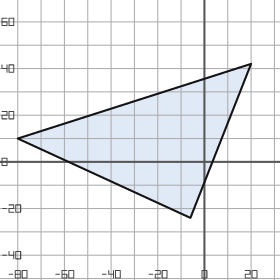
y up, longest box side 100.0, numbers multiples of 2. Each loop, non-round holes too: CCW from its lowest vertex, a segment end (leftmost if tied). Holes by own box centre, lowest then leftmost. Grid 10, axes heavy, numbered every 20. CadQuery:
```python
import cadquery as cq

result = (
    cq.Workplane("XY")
    .moveTo(-6.0, -24.0)
    .lineTo(20.0, 42.0)
    .lineTo(-80.0, 10.0)
    .close()
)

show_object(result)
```